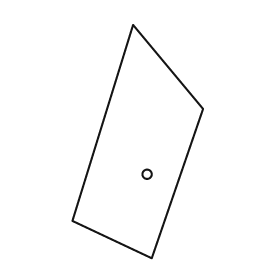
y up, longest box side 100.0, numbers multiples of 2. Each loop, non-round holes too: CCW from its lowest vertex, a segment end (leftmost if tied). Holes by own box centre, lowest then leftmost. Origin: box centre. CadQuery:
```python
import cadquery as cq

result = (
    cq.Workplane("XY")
    .moveTo(6.0, -50.0)
    .lineTo(28.0, 14.0)
    .lineTo(-2.0, 50.0)
    .lineTo(-28.0, -34.0)
    .close()
    .moveTo(4.0, -14.0)
    .circle(2.0)
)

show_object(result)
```